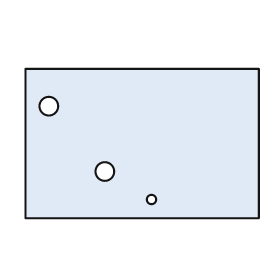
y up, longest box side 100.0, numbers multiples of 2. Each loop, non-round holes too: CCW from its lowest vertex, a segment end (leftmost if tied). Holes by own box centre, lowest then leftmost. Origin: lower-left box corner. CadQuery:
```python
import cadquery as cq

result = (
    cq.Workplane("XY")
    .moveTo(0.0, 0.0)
    .lineTo(100.0, 0.0)
    .lineTo(100.0, 64.0)
    .lineTo(0.0, 64.0)
    .close()
    .moveTo(54.0, 8.0)
    .circle(2.0)
    .moveTo(34.0, 20.0)
    .circle(4.0)
    .moveTo(10.0, 48.0)
    .circle(4.0)
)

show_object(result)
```